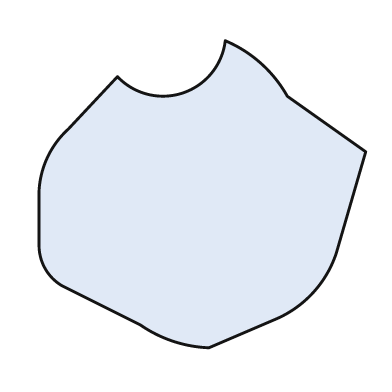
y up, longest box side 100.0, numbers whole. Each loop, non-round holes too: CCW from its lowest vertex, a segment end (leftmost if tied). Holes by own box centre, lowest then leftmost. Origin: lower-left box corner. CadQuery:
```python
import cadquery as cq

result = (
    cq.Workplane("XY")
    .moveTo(52.0, 0.0)
    .lineTo(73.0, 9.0)
    .threePointArc((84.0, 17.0), (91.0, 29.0))
    .lineTo(100.0, 60.0)
    .lineTo(76.0, 77.0)
    .threePointArc((68.0, 87.0), (57.0, 94.0))
    .threePointArc((44.0, 78.0), (24.0, 83.0))
    .lineTo(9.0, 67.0)
    .threePointArc((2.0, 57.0), (0.0, 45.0))
    .lineTo(0.0, 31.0)
    .threePointArc((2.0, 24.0), (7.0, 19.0))
    .lineTo(31.0, 7.0)
    .threePointArc((41.0, 2.0), (52.0, 0.0))
    .close()
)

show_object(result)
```